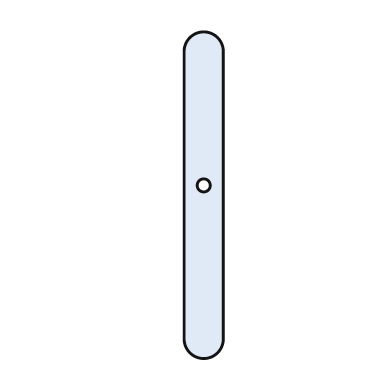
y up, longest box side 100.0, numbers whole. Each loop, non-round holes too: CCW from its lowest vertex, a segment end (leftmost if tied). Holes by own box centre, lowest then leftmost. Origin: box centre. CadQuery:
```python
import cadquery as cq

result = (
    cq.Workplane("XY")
    .moveTo(-6.0, -44.0)
    .threePointArc((0.0, -50.0), (6.0, -44.0))
    .lineTo(6.0, 44.0)
    .threePointArc((0.0, 50.0), (-6.0, 44.0))
    .close()
    .moveTo(0.0, 3.0)
    .circle(2.0)
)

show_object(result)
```